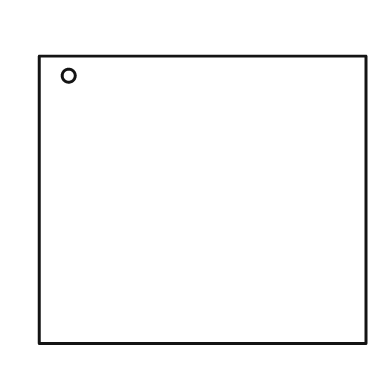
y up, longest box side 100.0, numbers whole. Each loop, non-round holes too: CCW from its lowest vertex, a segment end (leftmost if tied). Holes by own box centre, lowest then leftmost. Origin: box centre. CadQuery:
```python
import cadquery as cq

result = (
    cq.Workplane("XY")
    .moveTo(-50.0, -44.0)
    .lineTo(50.0, -44.0)
    .lineTo(50.0, 44.0)
    .lineTo(-50.0, 44.0)
    .close()
    .moveTo(-41.0, 38.0)
    .circle(2.0)
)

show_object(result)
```